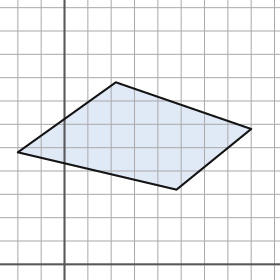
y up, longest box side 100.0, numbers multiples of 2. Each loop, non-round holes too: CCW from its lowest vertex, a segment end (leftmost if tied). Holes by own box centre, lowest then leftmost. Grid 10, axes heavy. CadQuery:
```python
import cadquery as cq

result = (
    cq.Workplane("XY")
    .moveTo(48.0, 32.0)
    .lineTo(80.0, 58.0)
    .lineTo(22.0, 78.0)
    .lineTo(-20.0, 48.0)
    .close()
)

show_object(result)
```